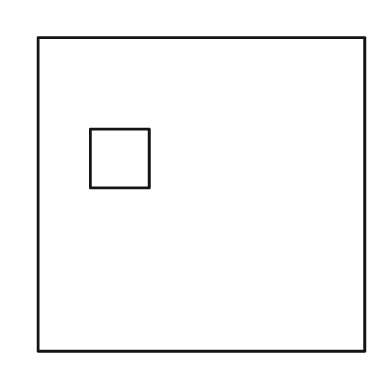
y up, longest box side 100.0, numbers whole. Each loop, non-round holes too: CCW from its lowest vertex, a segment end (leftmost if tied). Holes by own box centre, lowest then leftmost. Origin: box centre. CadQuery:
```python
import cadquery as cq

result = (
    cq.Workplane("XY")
    .moveTo(-50.0, -48.0)
    .lineTo(50.0, -48.0)
    .lineTo(50.0, 48.0)
    .lineTo(-50.0, 48.0)
    .close()
    .moveTo(-34.0, 2.0)
    .lineTo(-16.0, 2.0)
    .lineTo(-16.0, 20.0)
    .lineTo(-34.0, 20.0)
    .close()
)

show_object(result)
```